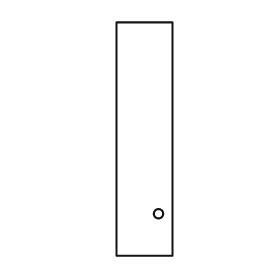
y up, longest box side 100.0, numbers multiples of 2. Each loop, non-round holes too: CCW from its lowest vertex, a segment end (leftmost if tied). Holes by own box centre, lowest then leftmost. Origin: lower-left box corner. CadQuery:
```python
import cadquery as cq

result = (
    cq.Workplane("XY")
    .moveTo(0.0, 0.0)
    .lineTo(24.0, 0.0)
    .lineTo(24.0, 100.0)
    .lineTo(0.0, 100.0)
    .close()
    .moveTo(18.0, 18.0)
    .circle(2.0)
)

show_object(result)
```